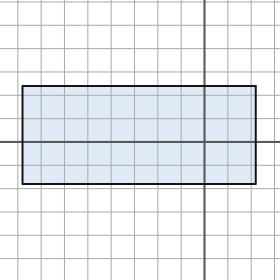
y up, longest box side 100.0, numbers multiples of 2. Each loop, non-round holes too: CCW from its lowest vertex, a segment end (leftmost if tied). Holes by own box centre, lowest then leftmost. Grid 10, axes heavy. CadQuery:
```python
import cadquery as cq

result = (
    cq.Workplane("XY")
    .moveTo(-78.0, -18.0)
    .lineTo(22.0, -18.0)
    .lineTo(22.0, 24.0)
    .lineTo(-78.0, 24.0)
    .close()
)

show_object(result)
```